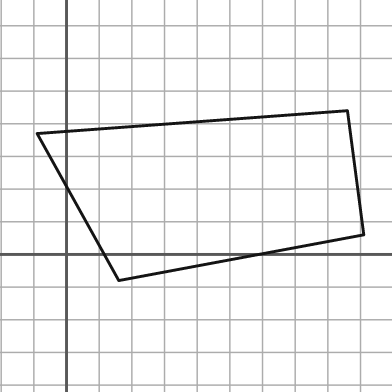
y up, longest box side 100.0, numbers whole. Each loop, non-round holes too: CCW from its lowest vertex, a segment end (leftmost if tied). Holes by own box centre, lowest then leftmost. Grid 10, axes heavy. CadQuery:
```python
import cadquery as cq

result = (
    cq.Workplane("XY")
    .moveTo(16.0, -8.0)
    .lineTo(91.0, 6.0)
    .lineTo(86.0, 44.0)
    .lineTo(-9.0, 37.0)
    .close()
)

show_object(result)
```